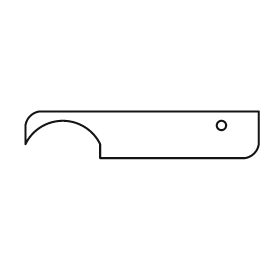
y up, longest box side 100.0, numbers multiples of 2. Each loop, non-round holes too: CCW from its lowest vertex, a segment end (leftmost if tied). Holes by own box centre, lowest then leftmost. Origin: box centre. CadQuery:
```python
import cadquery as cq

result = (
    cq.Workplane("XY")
    .moveTo(-18.0, -10.0)
    .lineTo(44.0, -10.0)
    .threePointArc((48.0, -8.0), (50.0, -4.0))
    .lineTo(50.0, 10.0)
    .lineTo(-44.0, 10.0)
    .threePointArc((-48.0, 8.0), (-50.0, 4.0))
    .lineTo(-50.0, -4.0)
    .threePointArc((-34.0, 6.0), (-18.0, -4.0))
    .close()
    .moveTo(34.0, 4.0)
    .circle(2.0)
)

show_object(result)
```